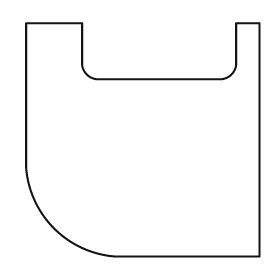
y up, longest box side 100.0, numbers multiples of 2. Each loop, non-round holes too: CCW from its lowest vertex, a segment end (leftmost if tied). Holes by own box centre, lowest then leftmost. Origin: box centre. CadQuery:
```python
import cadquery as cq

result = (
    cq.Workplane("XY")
    .moveTo(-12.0, -50.0)
    .lineTo(50.0, -50.0)
    .lineTo(50.0, 50.0)
    .lineTo(40.0, 50.0)
    .lineTo(40.0, 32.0)
    .threePointArc((38.0, 28.0), (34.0, 26.0))
    .lineTo(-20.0, 26.0)
    .threePointArc((-24.0, 28.0), (-26.0, 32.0))
    .lineTo(-26.0, 50.0)
    .lineTo(-50.0, 50.0)
    .lineTo(-50.0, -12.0)
    .threePointArc((-38.0, -38.0), (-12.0, -50.0))
    .close()
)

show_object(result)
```